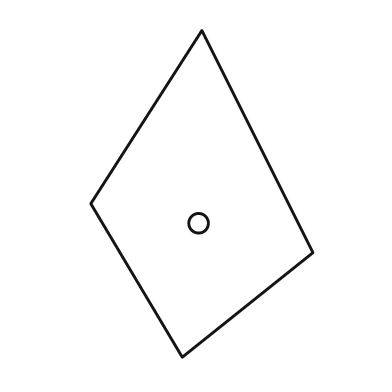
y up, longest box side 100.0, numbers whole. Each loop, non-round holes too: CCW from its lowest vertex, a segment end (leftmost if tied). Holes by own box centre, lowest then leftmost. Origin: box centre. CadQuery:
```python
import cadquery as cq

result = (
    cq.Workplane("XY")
    .moveTo(-6.0, -50.0)
    .lineTo(34.0, -18.0)
    .lineTo(0.0, 50.0)
    .lineTo(-34.0, -3.0)
    .close()
    .moveTo(-1.0, -9.0)
    .circle(3.0)
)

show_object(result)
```